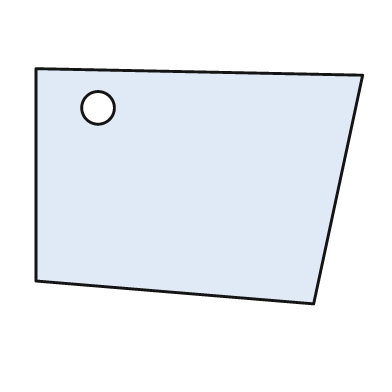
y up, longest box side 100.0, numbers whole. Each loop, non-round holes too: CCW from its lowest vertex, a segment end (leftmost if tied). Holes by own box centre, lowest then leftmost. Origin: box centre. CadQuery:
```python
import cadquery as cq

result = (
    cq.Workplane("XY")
    .moveTo(35.0, -36.0)
    .lineTo(50.0, 34.0)
    .lineTo(-50.0, 36.0)
    .lineTo(-50.0, -29.0)
    .close()
    .moveTo(-31.0, 24.0)
    .circle(5.0)
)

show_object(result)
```